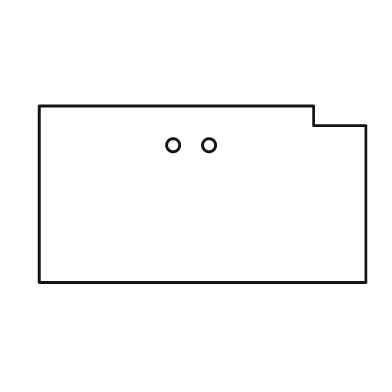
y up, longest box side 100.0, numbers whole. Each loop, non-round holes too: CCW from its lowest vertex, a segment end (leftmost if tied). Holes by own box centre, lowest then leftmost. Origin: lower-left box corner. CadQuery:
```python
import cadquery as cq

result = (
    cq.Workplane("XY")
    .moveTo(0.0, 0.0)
    .lineTo(100.0, 0.0)
    .lineTo(100.0, 48.0)
    .lineTo(84.0, 48.0)
    .lineTo(84.0, 54.0)
    .lineTo(0.0, 54.0)
    .close()
    .moveTo(41.0, 42.0)
    .circle(2.0)
    .moveTo(52.0, 42.0)
    .circle(2.0)
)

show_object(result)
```